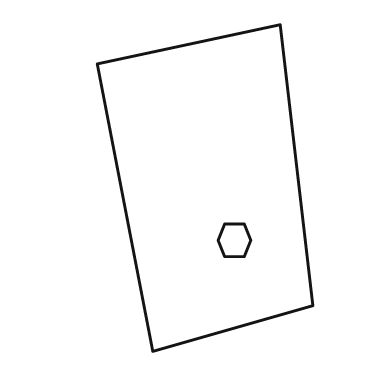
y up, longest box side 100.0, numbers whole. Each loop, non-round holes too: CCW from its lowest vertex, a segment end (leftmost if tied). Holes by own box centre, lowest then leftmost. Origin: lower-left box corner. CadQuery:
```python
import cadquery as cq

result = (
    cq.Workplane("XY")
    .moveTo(17.0, 0.0)
    .lineTo(66.0, 14.0)
    .lineTo(56.0, 100.0)
    .lineTo(0.0, 88.0)
    .close()
    .moveTo(39.0, 29.0)
    .lineTo(45.0, 29.0)
    .lineTo(47.0, 34.0)
    .lineTo(45.0, 39.0)
    .lineTo(39.0, 39.0)
    .lineTo(37.0, 34.0)
    .close()
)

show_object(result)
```